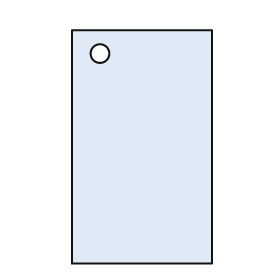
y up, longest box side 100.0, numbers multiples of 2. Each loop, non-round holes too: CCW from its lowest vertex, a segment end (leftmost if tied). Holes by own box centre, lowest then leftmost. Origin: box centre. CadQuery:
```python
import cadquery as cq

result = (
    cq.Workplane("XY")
    .moveTo(-30.0, -50.0)
    .lineTo(30.0, -50.0)
    .lineTo(30.0, 50.0)
    .lineTo(-30.0, 50.0)
    .close()
    .moveTo(-18.0, 40.0)
    .circle(4.0)
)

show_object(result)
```